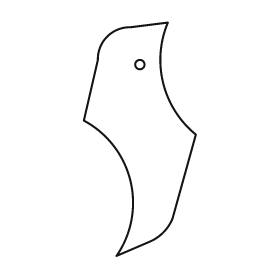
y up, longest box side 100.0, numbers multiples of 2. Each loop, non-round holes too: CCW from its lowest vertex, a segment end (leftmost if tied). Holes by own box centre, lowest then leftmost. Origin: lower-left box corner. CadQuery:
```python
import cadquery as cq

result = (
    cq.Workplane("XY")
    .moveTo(14.0, 0.0)
    .lineTo(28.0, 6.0)
    .threePointArc((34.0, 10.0), (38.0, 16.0))
    .lineTo(48.0, 52.0)
    .threePointArc((34.0, 74.0), (36.0, 100.0))
    .lineTo(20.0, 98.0)
    .threePointArc((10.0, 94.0), (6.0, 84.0))
    .lineTo(0.0, 58.0)
    .threePointArc((20.0, 32.0), (14.0, 0.0))
    .close()
    .moveTo(24.0, 82.0)
    .circle(2.0)
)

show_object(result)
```